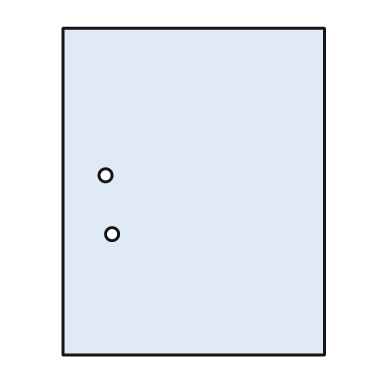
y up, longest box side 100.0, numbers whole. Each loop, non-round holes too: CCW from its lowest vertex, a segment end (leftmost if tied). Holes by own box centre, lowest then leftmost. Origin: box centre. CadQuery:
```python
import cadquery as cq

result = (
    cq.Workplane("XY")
    .moveTo(-40.0, -50.0)
    .lineTo(40.0, -50.0)
    .lineTo(40.0, 50.0)
    .lineTo(-40.0, 50.0)
    .close()
    .moveTo(-25.0, -13.0)
    .circle(2.0)
    .moveTo(-27.0, 5.0)
    .circle(2.0)
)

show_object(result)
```